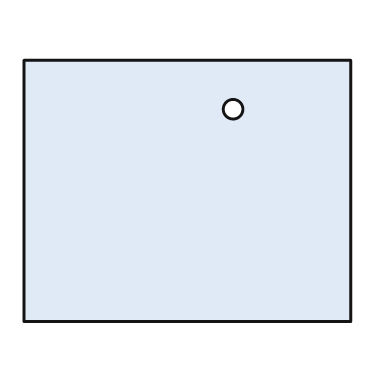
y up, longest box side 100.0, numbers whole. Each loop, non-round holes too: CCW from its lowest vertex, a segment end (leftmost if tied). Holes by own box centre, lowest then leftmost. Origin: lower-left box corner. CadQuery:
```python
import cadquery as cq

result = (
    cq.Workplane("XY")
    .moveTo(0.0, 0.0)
    .lineTo(100.0, 0.0)
    .lineTo(100.0, 80.0)
    .lineTo(0.0, 80.0)
    .close()
    .moveTo(64.0, 65.0)
    .circle(3.0)
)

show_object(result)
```